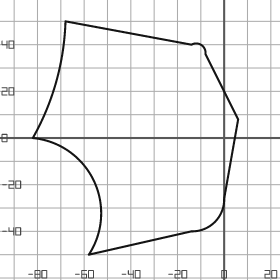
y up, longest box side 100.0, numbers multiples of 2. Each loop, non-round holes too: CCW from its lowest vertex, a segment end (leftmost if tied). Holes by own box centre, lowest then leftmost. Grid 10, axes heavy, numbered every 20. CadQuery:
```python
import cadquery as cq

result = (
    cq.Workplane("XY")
    .moveTo(-58.0, -50.0)
    .lineTo(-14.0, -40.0)
    .threePointArc((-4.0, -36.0), (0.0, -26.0))
    .lineTo(6.0, 8.0)
    .lineTo(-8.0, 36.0)
    .threePointArc((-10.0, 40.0), (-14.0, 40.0))
    .lineTo(-68.0, 50.0)
    .threePointArc((-72.0, 24.0), (-82.0, 0.0))
    .threePointArc((-56.0, -18.0), (-58.0, -50.0))
    .close()
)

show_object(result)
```